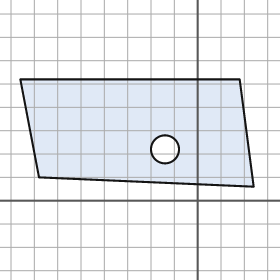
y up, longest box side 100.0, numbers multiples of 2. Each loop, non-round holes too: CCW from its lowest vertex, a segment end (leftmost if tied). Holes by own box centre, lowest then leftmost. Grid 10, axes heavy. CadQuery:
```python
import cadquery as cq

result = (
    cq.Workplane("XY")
    .moveTo(24.0, 6.0)
    .lineTo(18.0, 52.0)
    .lineTo(-76.0, 52.0)
    .lineTo(-68.0, 10.0)
    .close()
    .moveTo(-14.0, 22.0)
    .circle(6.0)
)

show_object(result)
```